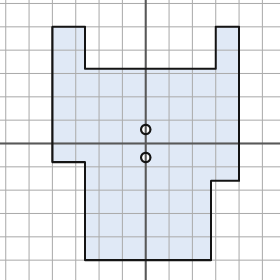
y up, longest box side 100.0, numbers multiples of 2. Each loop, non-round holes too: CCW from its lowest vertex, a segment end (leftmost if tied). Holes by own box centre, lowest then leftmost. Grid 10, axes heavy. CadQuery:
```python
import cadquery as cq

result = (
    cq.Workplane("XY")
    .moveTo(-26.0, -50.0)
    .lineTo(28.0, -50.0)
    .lineTo(28.0, -16.0)
    .lineTo(40.0, -16.0)
    .lineTo(40.0, 50.0)
    .lineTo(30.0, 50.0)
    .lineTo(30.0, 32.0)
    .lineTo(-26.0, 32.0)
    .lineTo(-26.0, 50.0)
    .lineTo(-40.0, 50.0)
    .lineTo(-40.0, -8.0)
    .lineTo(-26.0, -8.0)
    .close()
    .moveTo(0.0, -6.0)
    .circle(2.0)
    .moveTo(0.0, 6.0)
    .circle(2.0)
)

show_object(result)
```